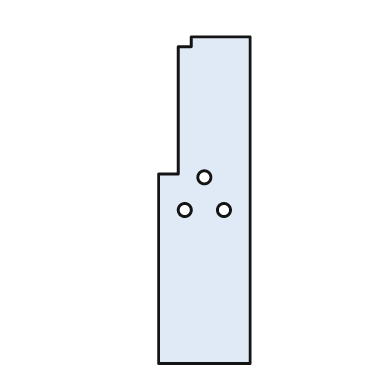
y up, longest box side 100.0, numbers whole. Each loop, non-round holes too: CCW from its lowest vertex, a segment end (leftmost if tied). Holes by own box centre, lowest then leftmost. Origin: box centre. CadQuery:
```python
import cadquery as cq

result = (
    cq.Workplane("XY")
    .moveTo(-14.0, -50.0)
    .lineTo(14.0, -50.0)
    .lineTo(14.0, 50.0)
    .lineTo(-4.0, 50.0)
    .lineTo(-4.0, 47.0)
    .lineTo(-8.0, 47.0)
    .lineTo(-8.0, 8.0)
    .lineTo(-14.0, 8.0)
    .close()
    .moveTo(-6.0, -3.0)
    .circle(2.0)
    .moveTo(6.0, -3.0)
    .circle(2.0)
    .moveTo(0.0, 7.0)
    .circle(2.0)
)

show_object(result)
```